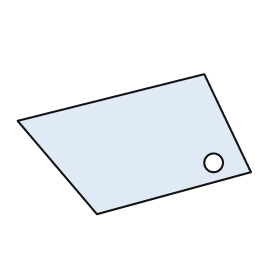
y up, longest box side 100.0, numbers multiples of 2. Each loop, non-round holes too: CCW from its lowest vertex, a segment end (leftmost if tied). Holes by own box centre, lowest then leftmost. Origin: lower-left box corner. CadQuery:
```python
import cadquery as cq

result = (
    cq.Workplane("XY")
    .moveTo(34.0, 0.0)
    .lineTo(100.0, 18.0)
    .lineTo(80.0, 60.0)
    .lineTo(0.0, 40.0)
    .close()
    .moveTo(84.0, 22.0)
    .circle(4.0)
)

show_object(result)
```